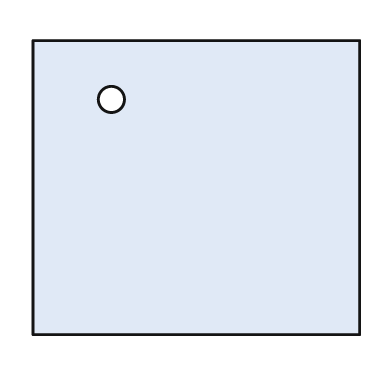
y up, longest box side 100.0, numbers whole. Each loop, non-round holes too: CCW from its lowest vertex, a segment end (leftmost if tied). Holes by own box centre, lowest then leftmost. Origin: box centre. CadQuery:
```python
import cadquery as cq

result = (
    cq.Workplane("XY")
    .moveTo(-50.0, -45.0)
    .lineTo(50.0, -45.0)
    .lineTo(50.0, 45.0)
    .lineTo(-50.0, 45.0)
    .close()
    .moveTo(-26.0, 27.0)
    .circle(4.0)
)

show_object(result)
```